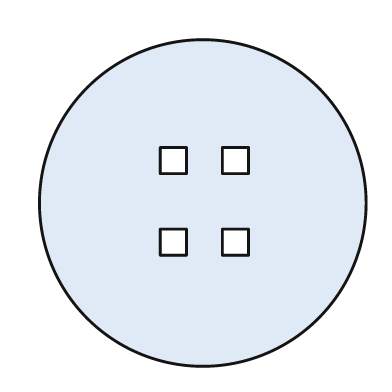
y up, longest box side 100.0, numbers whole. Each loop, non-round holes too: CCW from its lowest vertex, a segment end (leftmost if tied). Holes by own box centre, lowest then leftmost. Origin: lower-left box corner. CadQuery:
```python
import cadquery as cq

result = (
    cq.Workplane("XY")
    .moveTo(50.0, 50.0)
    .circle(50.0)
    .moveTo(37.0, 34.0)
    .lineTo(45.0, 34.0)
    .lineTo(45.0, 42.0)
    .lineTo(37.0, 42.0)
    .close()
    .moveTo(56.0, 34.0)
    .lineTo(64.0, 34.0)
    .lineTo(64.0, 42.0)
    .lineTo(56.0, 42.0)
    .close()
    .moveTo(37.0, 59.0)
    .lineTo(45.0, 59.0)
    .lineTo(45.0, 67.0)
    .lineTo(37.0, 67.0)
    .close()
    .moveTo(56.0, 59.0)
    .lineTo(64.0, 59.0)
    .lineTo(64.0, 67.0)
    .lineTo(56.0, 67.0)
    .close()
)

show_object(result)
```